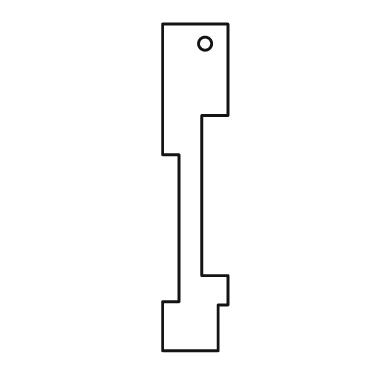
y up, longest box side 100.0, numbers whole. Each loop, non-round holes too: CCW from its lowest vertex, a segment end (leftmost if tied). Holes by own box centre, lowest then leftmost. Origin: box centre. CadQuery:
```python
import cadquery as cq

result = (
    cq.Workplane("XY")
    .moveTo(-10.0, -50.0)
    .lineTo(7.0, -50.0)
    .lineTo(7.0, -36.0)
    .lineTo(10.0, -36.0)
    .lineTo(10.0, -27.0)
    .lineTo(2.0, -27.0)
    .lineTo(2.0, 22.0)
    .lineTo(10.0, 22.0)
    .lineTo(10.0, 50.0)
    .lineTo(-10.0, 50.0)
    .lineTo(-10.0, 10.0)
    .lineTo(-5.0, 10.0)
    .lineTo(-5.0, -35.0)
    .lineTo(-10.0, -35.0)
    .close()
    .moveTo(3.0, 44.0)
    .circle(2.0)
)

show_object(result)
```